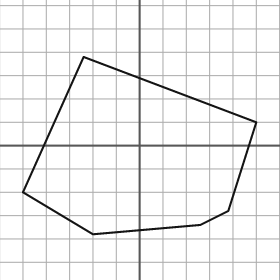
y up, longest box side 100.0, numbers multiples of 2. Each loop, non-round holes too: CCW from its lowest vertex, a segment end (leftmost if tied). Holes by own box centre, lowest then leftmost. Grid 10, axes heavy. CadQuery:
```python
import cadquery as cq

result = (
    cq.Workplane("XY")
    .moveTo(-20.0, -38.0)
    .lineTo(26.0, -34.0)
    .lineTo(38.0, -28.0)
    .lineTo(50.0, 10.0)
    .lineTo(-24.0, 38.0)
    .lineTo(-50.0, -20.0)
    .close()
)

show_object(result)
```